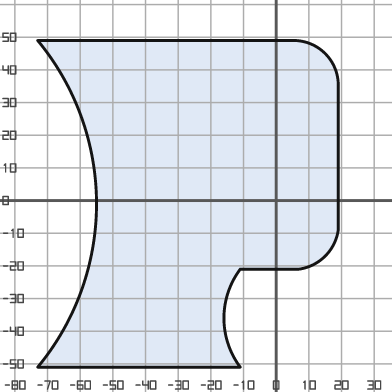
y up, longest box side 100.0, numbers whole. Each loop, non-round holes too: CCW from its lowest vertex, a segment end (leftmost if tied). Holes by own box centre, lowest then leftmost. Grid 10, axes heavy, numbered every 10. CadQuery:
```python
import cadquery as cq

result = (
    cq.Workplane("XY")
    .moveTo(-73.0, -51.0)
    .lineTo(-11.0, -51.0)
    .threePointArc((-16.0, -36.0), (-11.0, -21.0))
    .lineTo(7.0, -21.0)
    .threePointArc((15.0, -17.0), (19.0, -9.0))
    .lineTo(19.0, 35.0)
    .threePointArc((15.0, 45.0), (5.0, 49.0))
    .lineTo(-73.0, 49.0)
    .threePointArc((-55.0, -1.0), (-73.0, -51.0))
    .close()
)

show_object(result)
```